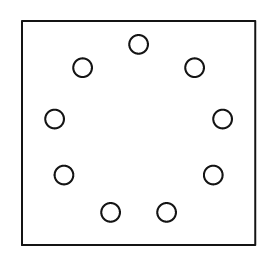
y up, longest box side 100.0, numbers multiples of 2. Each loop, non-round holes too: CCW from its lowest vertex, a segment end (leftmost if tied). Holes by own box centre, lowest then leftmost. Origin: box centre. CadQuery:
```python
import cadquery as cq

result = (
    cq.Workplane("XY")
    .moveTo(-50.0, -48.0)
    .lineTo(50.0, -48.0)
    .lineTo(50.0, 48.0)
    .lineTo(-50.0, 48.0)
    .close()
    .moveTo(-12.0, -34.0)
    .circle(4.0)
    .moveTo(12.0, -34.0)
    .circle(4.0)
    .moveTo(-32.0, -18.0)
    .circle(4.0)
    .moveTo(32.0, -18.0)
    .circle(4.0)
    .moveTo(-36.0, 6.0)
    .circle(4.0)
    .moveTo(36.0, 6.0)
    .circle(4.0)
    .moveTo(-24.0, 28.0)
    .circle(4.0)
    .moveTo(24.0, 28.0)
    .circle(4.0)
    .moveTo(0.0, 38.0)
    .circle(4.0)
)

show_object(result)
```